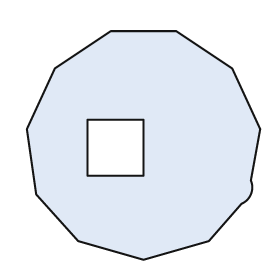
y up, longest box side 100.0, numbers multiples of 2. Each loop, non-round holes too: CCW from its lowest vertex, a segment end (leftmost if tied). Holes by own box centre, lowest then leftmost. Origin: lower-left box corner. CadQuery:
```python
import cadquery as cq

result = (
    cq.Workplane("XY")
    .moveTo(50.0, 0.0)
    .lineTo(78.0, 8.0)
    .lineTo(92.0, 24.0)
    .threePointArc((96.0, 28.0), (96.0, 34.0))
    .lineTo(100.0, 56.0)
    .lineTo(88.0, 82.0)
    .lineTo(64.0, 98.0)
    .lineTo(36.0, 98.0)
    .lineTo(12.0, 82.0)
    .lineTo(0.0, 56.0)
    .lineTo(4.0, 28.0)
    .lineTo(22.0, 8.0)
    .close()
    .moveTo(26.0, 36.0)
    .lineTo(50.0, 36.0)
    .lineTo(50.0, 60.0)
    .lineTo(26.0, 60.0)
    .close()
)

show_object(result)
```